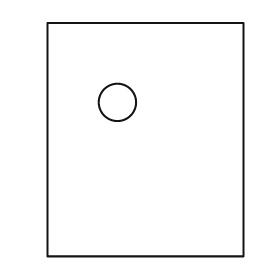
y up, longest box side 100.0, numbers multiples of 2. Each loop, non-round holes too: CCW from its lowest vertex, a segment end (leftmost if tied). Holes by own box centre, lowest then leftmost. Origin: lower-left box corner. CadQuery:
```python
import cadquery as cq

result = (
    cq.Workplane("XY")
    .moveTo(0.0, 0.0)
    .lineTo(84.0, 0.0)
    .lineTo(84.0, 100.0)
    .lineTo(0.0, 100.0)
    .close()
    .moveTo(30.0, 66.0)
    .circle(8.0)
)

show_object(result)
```